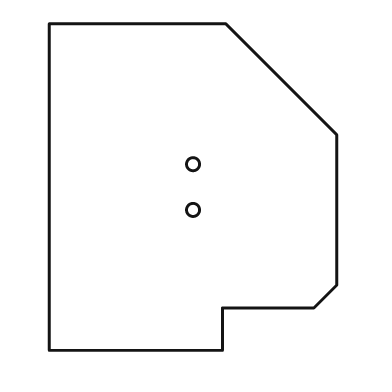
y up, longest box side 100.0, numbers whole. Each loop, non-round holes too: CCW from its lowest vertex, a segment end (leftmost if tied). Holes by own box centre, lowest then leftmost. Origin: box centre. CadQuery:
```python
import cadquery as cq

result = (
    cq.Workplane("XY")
    .moveTo(-44.0, -50.0)
    .lineTo(9.0, -50.0)
    .lineTo(9.0, -37.0)
    .lineTo(37.0, -37.0)
    .lineTo(44.0, -30.0)
    .lineTo(44.0, 16.0)
    .lineTo(10.0, 50.0)
    .lineTo(-44.0, 50.0)
    .close()
    .moveTo(0.0, -7.0)
    .circle(2.0)
    .moveTo(0.0, 7.0)
    .circle(2.0)
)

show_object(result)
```